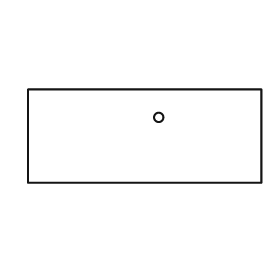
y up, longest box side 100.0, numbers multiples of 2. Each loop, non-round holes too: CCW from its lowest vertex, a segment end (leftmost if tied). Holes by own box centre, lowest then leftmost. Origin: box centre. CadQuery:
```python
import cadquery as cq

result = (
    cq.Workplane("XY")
    .moveTo(-50.0, -20.0)
    .lineTo(50.0, -20.0)
    .lineTo(50.0, 20.0)
    .lineTo(-50.0, 20.0)
    .close()
    .moveTo(6.0, 8.0)
    .circle(2.0)
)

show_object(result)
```